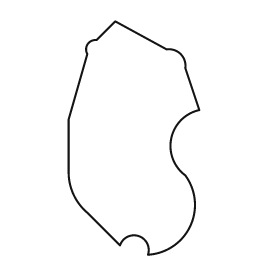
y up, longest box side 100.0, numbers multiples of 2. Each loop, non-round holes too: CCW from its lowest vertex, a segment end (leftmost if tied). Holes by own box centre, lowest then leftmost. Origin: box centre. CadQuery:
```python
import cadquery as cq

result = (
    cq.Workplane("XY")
    .moveTo(6.0, -50.0)
    .threePointArc((24.0, -38.0), (22.0, -16.0))
    .threePointArc((16.0, 0.0), (28.0, 12.0))
    .lineTo(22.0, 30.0)
    .threePointArc((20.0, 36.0), (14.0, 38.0))
    .lineTo(-8.0, 50.0)
    .lineTo(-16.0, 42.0)
    .threePointArc((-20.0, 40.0), (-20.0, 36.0))
    .lineTo(-28.0, 8.0)
    .lineTo(-28.0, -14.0)
    .threePointArc((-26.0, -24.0), (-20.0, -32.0))
    .lineTo(-6.0, -46.0)
    .threePointArc((2.0, -42.0), (6.0, -50.0))
    .close()
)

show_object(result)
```